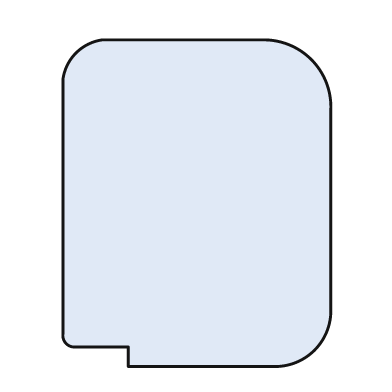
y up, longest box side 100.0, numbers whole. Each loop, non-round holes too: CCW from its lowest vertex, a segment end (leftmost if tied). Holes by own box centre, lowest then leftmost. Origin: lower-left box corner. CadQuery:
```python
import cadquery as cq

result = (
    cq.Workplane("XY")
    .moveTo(20.0, 0.0)
    .lineTo(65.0, 0.0)
    .threePointArc((77.0, 5.0), (82.0, 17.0))
    .lineTo(82.0, 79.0)
    .threePointArc((76.0, 94.0), (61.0, 100.0))
    .lineTo(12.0, 100.0)
    .threePointArc((4.0, 96.0), (0.0, 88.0))
    .lineTo(0.0, 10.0)
    .threePointArc((1.0, 7.0), (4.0, 6.0))
    .lineTo(20.0, 6.0)
    .close()
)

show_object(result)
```